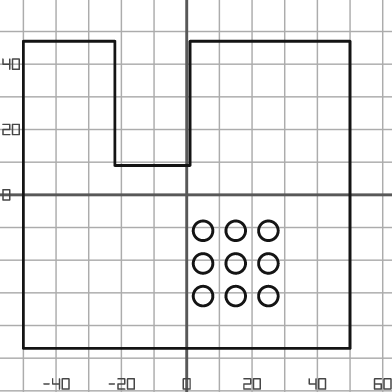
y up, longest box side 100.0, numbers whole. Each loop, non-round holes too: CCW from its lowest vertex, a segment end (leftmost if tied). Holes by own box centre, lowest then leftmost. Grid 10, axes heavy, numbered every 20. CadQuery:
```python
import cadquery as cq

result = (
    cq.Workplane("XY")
    .moveTo(-50.0, -47.0)
    .lineTo(50.0, -47.0)
    .lineTo(50.0, 47.0)
    .lineTo(1.0, 47.0)
    .lineTo(1.0, 9.0)
    .lineTo(-22.0, 9.0)
    .lineTo(-22.0, 47.0)
    .lineTo(-50.0, 47.0)
    .close()
    .moveTo(5.0, -31.0)
    .circle(3.0)
    .moveTo(15.0, -31.0)
    .circle(3.0)
    .moveTo(25.0, -31.0)
    .circle(3.0)
    .moveTo(5.0, -21.0)
    .circle(3.0)
    .moveTo(15.0, -21.0)
    .circle(3.0)
    .moveTo(25.0, -21.0)
    .circle(3.0)
    .moveTo(5.0, -11.0)
    .circle(3.0)
    .moveTo(15.0, -11.0)
    .circle(3.0)
    .moveTo(25.0, -11.0)
    .circle(3.0)
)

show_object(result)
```